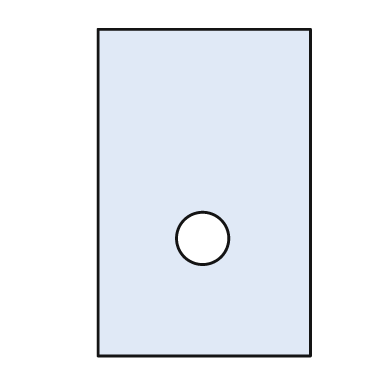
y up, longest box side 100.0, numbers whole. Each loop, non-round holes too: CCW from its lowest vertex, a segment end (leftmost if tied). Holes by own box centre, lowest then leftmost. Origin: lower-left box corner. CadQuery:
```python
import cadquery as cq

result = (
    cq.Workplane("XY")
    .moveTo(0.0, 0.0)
    .lineTo(65.0, 0.0)
    .lineTo(65.0, 100.0)
    .lineTo(0.0, 100.0)
    .close()
    .moveTo(32.0, 36.0)
    .circle(8.0)
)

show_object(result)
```